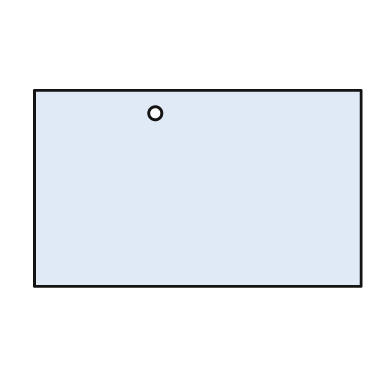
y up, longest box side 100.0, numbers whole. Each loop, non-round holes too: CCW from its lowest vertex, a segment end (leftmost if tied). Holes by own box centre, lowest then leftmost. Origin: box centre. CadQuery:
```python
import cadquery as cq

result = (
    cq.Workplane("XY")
    .moveTo(-50.0, -30.0)
    .lineTo(50.0, -30.0)
    .lineTo(50.0, 30.0)
    .lineTo(-50.0, 30.0)
    .close()
    .moveTo(-13.0, 23.0)
    .circle(2.0)
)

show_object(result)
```